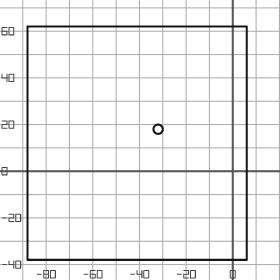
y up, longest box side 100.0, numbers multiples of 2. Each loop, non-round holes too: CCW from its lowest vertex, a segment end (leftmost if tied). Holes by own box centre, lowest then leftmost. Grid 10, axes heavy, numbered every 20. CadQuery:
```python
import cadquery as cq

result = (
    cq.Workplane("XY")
    .moveTo(-88.0, -38.0)
    .lineTo(6.0, -38.0)
    .lineTo(6.0, 62.0)
    .lineTo(-88.0, 62.0)
    .close()
    .moveTo(-32.0, 18.0)
    .circle(2.0)
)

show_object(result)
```